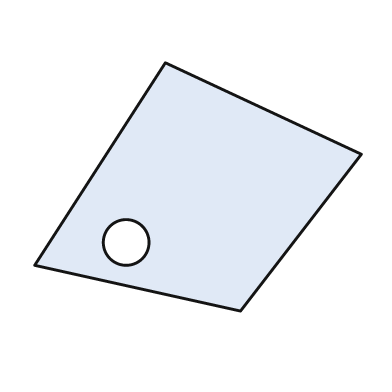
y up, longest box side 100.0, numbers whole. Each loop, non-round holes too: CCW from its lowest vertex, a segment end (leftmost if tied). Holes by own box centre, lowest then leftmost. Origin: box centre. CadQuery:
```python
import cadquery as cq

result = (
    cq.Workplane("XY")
    .moveTo(13.0, -38.0)
    .lineTo(50.0, 10.0)
    .lineTo(-10.0, 38.0)
    .lineTo(-50.0, -24.0)
    .close()
    .moveTo(-22.0, -17.0)
    .circle(7.0)
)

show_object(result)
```